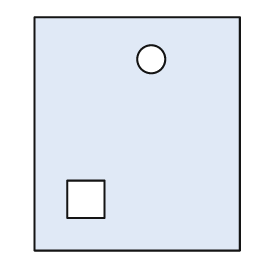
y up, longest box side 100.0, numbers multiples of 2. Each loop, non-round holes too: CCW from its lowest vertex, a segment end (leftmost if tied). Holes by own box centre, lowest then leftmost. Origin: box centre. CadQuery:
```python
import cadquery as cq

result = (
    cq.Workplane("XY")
    .moveTo(-44.0, -50.0)
    .lineTo(44.0, -50.0)
    .lineTo(44.0, 50.0)
    .lineTo(-44.0, 50.0)
    .close()
    .moveTo(-30.0, -36.0)
    .lineTo(-14.0, -36.0)
    .lineTo(-14.0, -20.0)
    .lineTo(-30.0, -20.0)
    .close()
    .moveTo(6.0, 32.0)
    .circle(6.0)
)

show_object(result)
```